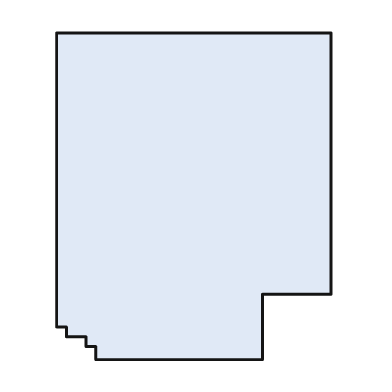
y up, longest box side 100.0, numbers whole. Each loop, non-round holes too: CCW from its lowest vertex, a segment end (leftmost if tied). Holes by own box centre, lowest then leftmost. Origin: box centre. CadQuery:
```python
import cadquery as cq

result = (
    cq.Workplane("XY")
    .moveTo(-30.0, -50.0)
    .lineTo(21.0, -50.0)
    .lineTo(21.0, -30.0)
    .lineTo(42.0, -30.0)
    .lineTo(42.0, 50.0)
    .lineTo(-42.0, 50.0)
    .lineTo(-42.0, -40.0)
    .lineTo(-39.0, -40.0)
    .lineTo(-39.0, -43.0)
    .lineTo(-33.0, -43.0)
    .lineTo(-33.0, -46.0)
    .lineTo(-30.0, -46.0)
    .close()
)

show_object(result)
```